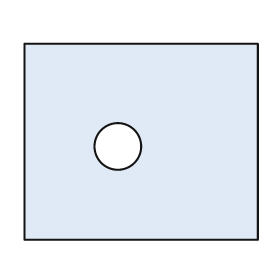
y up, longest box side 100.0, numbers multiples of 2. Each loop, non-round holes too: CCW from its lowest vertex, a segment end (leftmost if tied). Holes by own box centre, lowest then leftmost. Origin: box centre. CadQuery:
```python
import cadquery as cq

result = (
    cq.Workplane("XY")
    .moveTo(-50.0, -42.0)
    .lineTo(50.0, -42.0)
    .lineTo(50.0, 42.0)
    .lineTo(-50.0, 42.0)
    .close()
    .moveTo(-10.0, -2.0)
    .circle(10.0)
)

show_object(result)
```